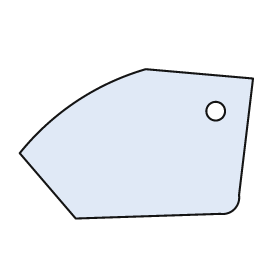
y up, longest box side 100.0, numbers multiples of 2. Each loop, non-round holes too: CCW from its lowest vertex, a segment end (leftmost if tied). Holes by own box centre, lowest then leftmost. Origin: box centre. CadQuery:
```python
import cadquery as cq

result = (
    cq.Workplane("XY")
    .moveTo(-26.0, -32.0)
    .lineTo(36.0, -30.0)
    .threePointArc((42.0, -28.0), (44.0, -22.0))
    .lineTo(50.0, 28.0)
    .lineTo(4.0, 32.0)
    .threePointArc((-26.0, 18.0), (-50.0, -4.0))
    .close()
    .moveTo(34.0, 14.0)
    .circle(4.0)
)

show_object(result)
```